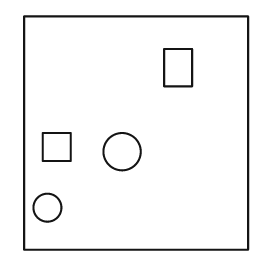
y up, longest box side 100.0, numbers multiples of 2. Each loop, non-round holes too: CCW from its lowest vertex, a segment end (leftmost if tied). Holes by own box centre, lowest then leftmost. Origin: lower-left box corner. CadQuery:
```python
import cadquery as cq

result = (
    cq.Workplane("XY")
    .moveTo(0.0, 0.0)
    .lineTo(96.0, 0.0)
    .lineTo(96.0, 100.0)
    .lineTo(0.0, 100.0)
    .close()
    .moveTo(10.0, 18.0)
    .circle(6.0)
    .moveTo(42.0, 42.0)
    .circle(8.0)
    .moveTo(8.0, 38.0)
    .lineTo(20.0, 38.0)
    .lineTo(20.0, 50.0)
    .lineTo(8.0, 50.0)
    .close()
    .moveTo(60.0, 70.0)
    .lineTo(72.0, 70.0)
    .lineTo(72.0, 86.0)
    .lineTo(60.0, 86.0)
    .close()
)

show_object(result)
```